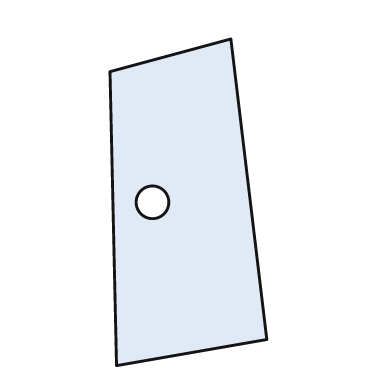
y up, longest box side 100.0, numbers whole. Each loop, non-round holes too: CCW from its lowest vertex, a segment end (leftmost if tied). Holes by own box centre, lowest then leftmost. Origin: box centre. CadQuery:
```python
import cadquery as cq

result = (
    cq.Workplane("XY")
    .moveTo(-22.0, -50.0)
    .lineTo(24.0, -42.0)
    .lineTo(13.0, 50.0)
    .lineTo(-24.0, 40.0)
    .close()
    .moveTo(-11.0, 0.0)
    .circle(5.0)
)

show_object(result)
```